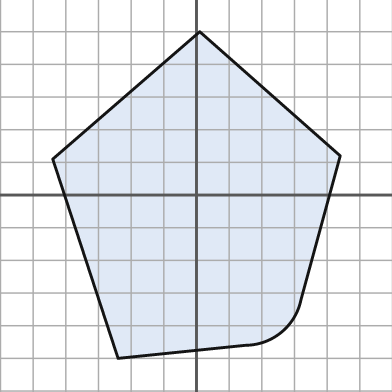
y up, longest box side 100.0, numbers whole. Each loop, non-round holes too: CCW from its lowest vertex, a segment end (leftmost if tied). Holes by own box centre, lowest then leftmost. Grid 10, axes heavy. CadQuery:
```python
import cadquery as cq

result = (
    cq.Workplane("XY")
    .moveTo(-24.0, -50.0)
    .lineTo(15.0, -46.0)
    .threePointArc((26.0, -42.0), (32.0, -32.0))
    .lineTo(44.0, 12.0)
    .lineTo(1.0, 50.0)
    .lineTo(-44.0, 11.0)
    .close()
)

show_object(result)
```